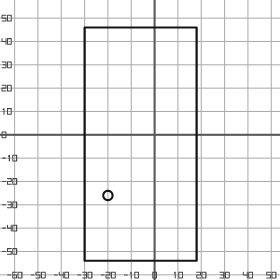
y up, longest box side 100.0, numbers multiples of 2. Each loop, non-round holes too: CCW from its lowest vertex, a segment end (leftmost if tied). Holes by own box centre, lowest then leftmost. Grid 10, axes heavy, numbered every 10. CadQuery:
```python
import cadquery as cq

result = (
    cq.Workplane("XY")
    .moveTo(-30.0, -54.0)
    .lineTo(18.0, -54.0)
    .lineTo(18.0, 46.0)
    .lineTo(-30.0, 46.0)
    .close()
    .moveTo(-20.0, -26.0)
    .circle(2.0)
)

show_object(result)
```